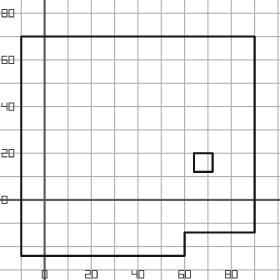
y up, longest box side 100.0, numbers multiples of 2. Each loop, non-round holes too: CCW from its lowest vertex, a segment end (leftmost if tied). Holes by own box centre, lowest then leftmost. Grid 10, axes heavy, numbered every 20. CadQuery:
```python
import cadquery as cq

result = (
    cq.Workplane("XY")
    .moveTo(-10.0, -24.0)
    .lineTo(60.0, -24.0)
    .lineTo(60.0, -14.0)
    .lineTo(90.0, -14.0)
    .lineTo(90.0, 70.0)
    .lineTo(-10.0, 70.0)
    .close()
    .moveTo(64.0, 12.0)
    .lineTo(72.0, 12.0)
    .lineTo(72.0, 20.0)
    .lineTo(64.0, 20.0)
    .close()
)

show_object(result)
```